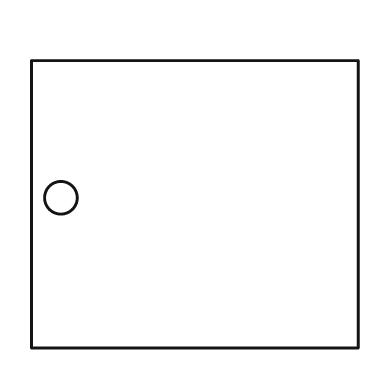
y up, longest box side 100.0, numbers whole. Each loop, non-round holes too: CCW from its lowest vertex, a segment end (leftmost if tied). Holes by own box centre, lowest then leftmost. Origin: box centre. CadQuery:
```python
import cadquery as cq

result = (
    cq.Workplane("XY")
    .moveTo(-50.0, -44.0)
    .lineTo(50.0, -44.0)
    .lineTo(50.0, 44.0)
    .lineTo(-50.0, 44.0)
    .close()
    .moveTo(-41.0, 2.0)
    .circle(5.0)
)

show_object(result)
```